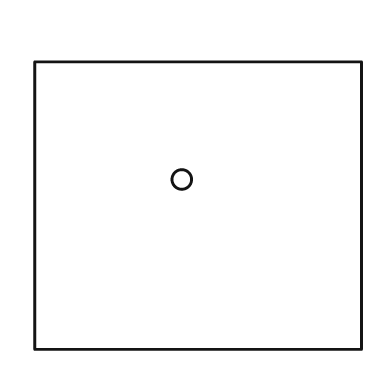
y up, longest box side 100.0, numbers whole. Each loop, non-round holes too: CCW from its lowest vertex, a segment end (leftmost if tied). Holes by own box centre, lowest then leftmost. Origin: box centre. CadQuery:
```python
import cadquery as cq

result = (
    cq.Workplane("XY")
    .moveTo(-50.0, -44.0)
    .lineTo(50.0, -44.0)
    .lineTo(50.0, 44.0)
    .lineTo(-50.0, 44.0)
    .close()
    .moveTo(-5.0, 8.0)
    .circle(3.0)
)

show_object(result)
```